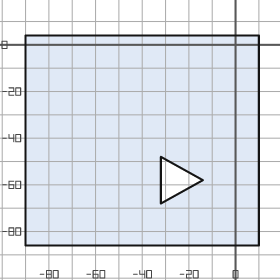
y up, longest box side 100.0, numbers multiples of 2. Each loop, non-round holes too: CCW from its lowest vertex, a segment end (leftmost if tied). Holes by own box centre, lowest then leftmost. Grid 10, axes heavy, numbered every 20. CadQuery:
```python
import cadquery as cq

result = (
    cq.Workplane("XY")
    .moveTo(-90.0, -86.0)
    .lineTo(10.0, -86.0)
    .lineTo(10.0, 4.0)
    .lineTo(-90.0, 4.0)
    .close()
    .moveTo(-32.0, -68.0)
    .lineTo(-14.0, -58.0)
    .lineTo(-32.0, -48.0)
    .close()
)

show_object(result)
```